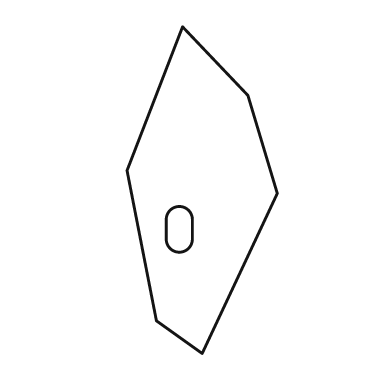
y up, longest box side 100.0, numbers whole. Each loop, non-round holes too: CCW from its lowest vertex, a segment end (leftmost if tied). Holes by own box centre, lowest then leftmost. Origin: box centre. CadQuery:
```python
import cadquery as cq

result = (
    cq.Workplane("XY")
    .moveTo(0.0, -50.0)
    .lineTo(23.0, -1.0)
    .lineTo(14.0, 29.0)
    .lineTo(-6.0, 50.0)
    .lineTo(-23.0, 6.0)
    .lineTo(-14.0, -40.0)
    .close()
    .moveTo(-11.0, -15.0)
    .threePointArc((-7.0, -19.0), (-3.0, -15.0))
    .lineTo(-3.0, -9.0)
    .threePointArc((-7.0, -5.0), (-11.0, -9.0))
    .close()
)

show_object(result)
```